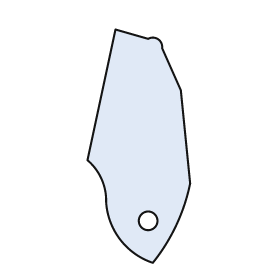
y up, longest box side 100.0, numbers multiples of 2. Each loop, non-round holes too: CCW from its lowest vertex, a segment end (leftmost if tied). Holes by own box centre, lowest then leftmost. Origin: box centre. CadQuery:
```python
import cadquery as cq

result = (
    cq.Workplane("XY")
    .moveTo(6.0, -50.0)
    .threePointArc((16.0, -34.0), (22.0, -16.0))
    .lineTo(18.0, 24.0)
    .lineTo(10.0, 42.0)
    .threePointArc((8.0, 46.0), (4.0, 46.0))
    .lineTo(-10.0, 50.0)
    .lineTo(-22.0, -6.0)
    .threePointArc((-16.0, -14.0), (-14.0, -24.0))
    .threePointArc((-8.0, -40.0), (6.0, -50.0))
    .close()
    .moveTo(4.0, -32.0)
    .circle(4.0)
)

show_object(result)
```